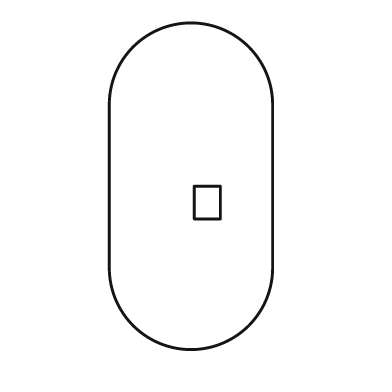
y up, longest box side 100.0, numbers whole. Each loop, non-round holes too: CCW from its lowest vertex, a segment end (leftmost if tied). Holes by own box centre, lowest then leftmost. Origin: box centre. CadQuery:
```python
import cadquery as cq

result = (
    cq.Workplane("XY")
    .moveTo(-25.0, -25.0)
    .threePointArc((0.0, -50.0), (25.0, -25.0))
    .lineTo(25.0, 25.0)
    .threePointArc((0.0, 50.0), (-25.0, 25.0))
    .close()
    .moveTo(1.0, -10.0)
    .lineTo(9.0, -10.0)
    .lineTo(9.0, 0.0)
    .lineTo(1.0, 0.0)
    .close()
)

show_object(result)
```